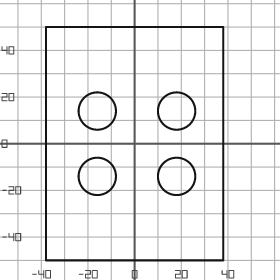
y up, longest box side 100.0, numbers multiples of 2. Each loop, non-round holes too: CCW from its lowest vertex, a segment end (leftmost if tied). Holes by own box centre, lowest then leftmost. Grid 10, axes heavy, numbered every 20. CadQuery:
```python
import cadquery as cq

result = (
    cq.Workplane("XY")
    .moveTo(-38.0, -50.0)
    .lineTo(38.0, -50.0)
    .lineTo(38.0, 50.0)
    .lineTo(-38.0, 50.0)
    .close()
    .moveTo(-16.0, -14.0)
    .circle(8.0)
    .moveTo(18.0, -14.0)
    .circle(8.0)
    .moveTo(-16.0, 14.0)
    .circle(8.0)
    .moveTo(18.0, 14.0)
    .circle(8.0)
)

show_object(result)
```